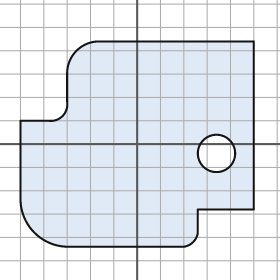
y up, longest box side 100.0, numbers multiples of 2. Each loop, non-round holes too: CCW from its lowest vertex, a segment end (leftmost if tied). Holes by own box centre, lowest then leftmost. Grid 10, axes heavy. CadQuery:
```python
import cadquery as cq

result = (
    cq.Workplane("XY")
    .moveTo(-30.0, -44.0)
    .lineTo(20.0, -44.0)
    .threePointArc((24.0, -42.0), (26.0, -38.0))
    .lineTo(26.0, -28.0)
    .lineTo(50.0, -28.0)
    .lineTo(50.0, 44.0)
    .lineTo(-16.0, 44.0)
    .threePointArc((-26.0, 40.0), (-30.0, 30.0))
    .lineTo(-30.0, 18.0)
    .threePointArc((-32.0, 12.0), (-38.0, 10.0))
    .lineTo(-50.0, 10.0)
    .lineTo(-50.0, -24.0)
    .threePointArc((-44.0, -38.0), (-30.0, -44.0))
    .close()
    .moveTo(34.0, -4.0)
    .circle(8.0)
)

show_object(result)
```